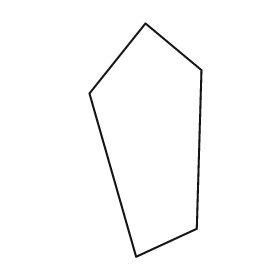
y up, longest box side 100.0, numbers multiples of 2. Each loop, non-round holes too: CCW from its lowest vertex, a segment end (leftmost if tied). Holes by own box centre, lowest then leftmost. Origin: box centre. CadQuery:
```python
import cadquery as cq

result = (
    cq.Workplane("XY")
    .moveTo(-4.0, -50.0)
    .lineTo(22.0, -38.0)
    .lineTo(24.0, 30.0)
    .lineTo(0.0, 50.0)
    .lineTo(-24.0, 20.0)
    .close()
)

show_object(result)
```